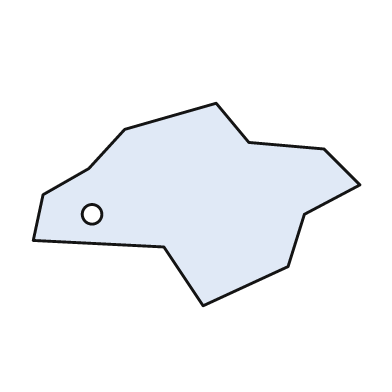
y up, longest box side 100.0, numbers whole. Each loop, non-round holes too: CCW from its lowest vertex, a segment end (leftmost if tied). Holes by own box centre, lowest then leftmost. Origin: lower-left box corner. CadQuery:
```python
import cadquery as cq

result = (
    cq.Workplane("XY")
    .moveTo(52.0, 0.0)
    .lineTo(78.0, 12.0)
    .lineTo(83.0, 28.0)
    .lineTo(100.0, 37.0)
    .lineTo(89.0, 48.0)
    .lineTo(66.0, 50.0)
    .lineTo(56.0, 62.0)
    .lineTo(28.0, 54.0)
    .lineTo(17.0, 42.0)
    .lineTo(3.0, 34.0)
    .lineTo(0.0, 20.0)
    .lineTo(40.0, 18.0)
    .close()
    .moveTo(18.0, 28.0)
    .circle(3.0)
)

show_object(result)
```